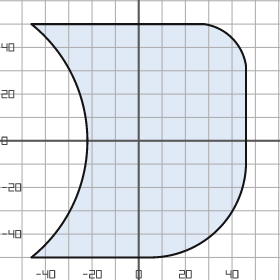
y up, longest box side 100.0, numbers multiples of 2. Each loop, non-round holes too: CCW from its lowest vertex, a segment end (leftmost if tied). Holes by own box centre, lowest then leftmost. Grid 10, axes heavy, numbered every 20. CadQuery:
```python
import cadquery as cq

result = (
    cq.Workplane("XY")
    .moveTo(-46.0, -50.0)
    .lineTo(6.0, -50.0)
    .threePointArc((34.0, -38.0), (46.0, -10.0))
    .lineTo(46.0, 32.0)
    .threePointArc((40.0, 44.0), (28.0, 50.0))
    .lineTo(-46.0, 50.0)
    .threePointArc((-22.0, 0.0), (-46.0, -50.0))
    .close()
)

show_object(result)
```